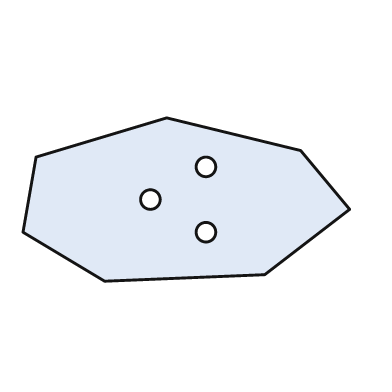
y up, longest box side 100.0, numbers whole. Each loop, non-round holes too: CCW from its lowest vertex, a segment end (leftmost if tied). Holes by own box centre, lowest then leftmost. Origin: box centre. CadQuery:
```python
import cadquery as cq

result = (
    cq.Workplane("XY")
    .moveTo(-25.0, -25.0)
    .lineTo(24.0, -23.0)
    .lineTo(50.0, -3.0)
    .lineTo(35.0, 15.0)
    .lineTo(-6.0, 25.0)
    .lineTo(-46.0, 13.0)
    .lineTo(-50.0, -10.0)
    .close()
    .moveTo(6.0, -10.0)
    .circle(3.0)
    .moveTo(-11.0, 0.0)
    .circle(3.0)
    .moveTo(6.0, 10.0)
    .circle(3.0)
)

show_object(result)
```